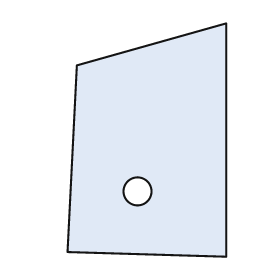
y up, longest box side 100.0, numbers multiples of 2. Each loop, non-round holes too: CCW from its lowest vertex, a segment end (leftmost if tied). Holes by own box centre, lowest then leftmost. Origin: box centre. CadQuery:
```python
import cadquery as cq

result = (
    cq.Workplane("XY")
    .moveTo(34.0, -50.0)
    .lineTo(34.0, 50.0)
    .lineTo(-30.0, 32.0)
    .lineTo(-34.0, -48.0)
    .close()
    .moveTo(-4.0, -22.0)
    .circle(6.0)
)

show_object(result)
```